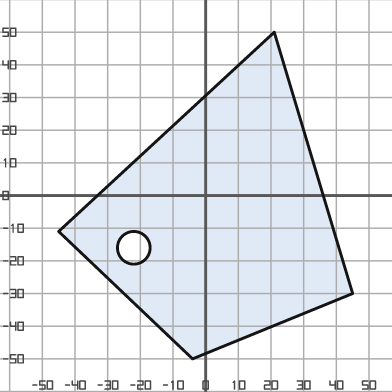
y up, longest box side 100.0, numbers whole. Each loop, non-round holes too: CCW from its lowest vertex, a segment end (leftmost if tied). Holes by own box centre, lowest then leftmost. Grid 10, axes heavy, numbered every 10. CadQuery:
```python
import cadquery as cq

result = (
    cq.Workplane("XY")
    .moveTo(-4.0, -50.0)
    .lineTo(45.0, -30.0)
    .lineTo(21.0, 50.0)
    .lineTo(-45.0, -11.0)
    .close()
    .moveTo(-22.0, -16.0)
    .circle(5.0)
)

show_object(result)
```